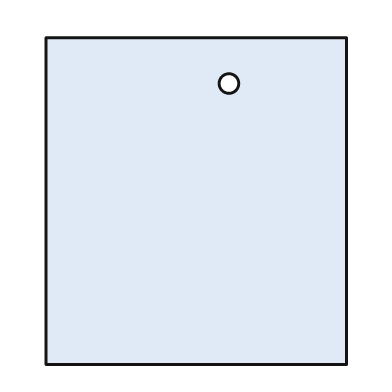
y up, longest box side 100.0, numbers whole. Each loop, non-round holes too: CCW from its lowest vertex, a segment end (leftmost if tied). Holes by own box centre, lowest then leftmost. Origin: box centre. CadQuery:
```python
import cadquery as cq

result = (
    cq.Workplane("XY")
    .moveTo(-46.0, -50.0)
    .lineTo(46.0, -50.0)
    .lineTo(46.0, 50.0)
    .lineTo(-46.0, 50.0)
    .close()
    .moveTo(10.0, 36.0)
    .circle(3.0)
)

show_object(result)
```